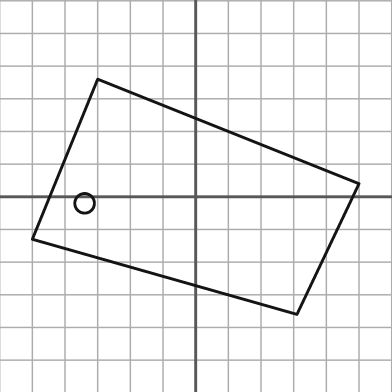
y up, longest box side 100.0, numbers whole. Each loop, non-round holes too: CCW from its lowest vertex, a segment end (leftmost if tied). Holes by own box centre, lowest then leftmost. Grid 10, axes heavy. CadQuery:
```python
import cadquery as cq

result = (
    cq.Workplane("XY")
    .moveTo(31.0, -36.0)
    .lineTo(50.0, 4.0)
    .lineTo(-30.0, 36.0)
    .lineTo(-50.0, -13.0)
    .close()
    .moveTo(-34.0, -2.0)
    .circle(3.0)
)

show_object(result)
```